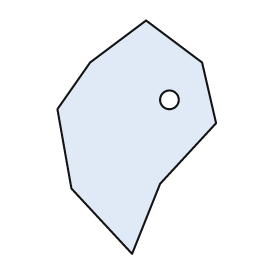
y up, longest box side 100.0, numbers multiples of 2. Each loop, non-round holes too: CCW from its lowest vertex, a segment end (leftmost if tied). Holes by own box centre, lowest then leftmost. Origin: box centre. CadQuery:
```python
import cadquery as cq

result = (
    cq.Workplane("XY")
    .moveTo(-2.0, -50.0)
    .lineTo(10.0, -20.0)
    .lineTo(34.0, 6.0)
    .lineTo(28.0, 32.0)
    .lineTo(4.0, 50.0)
    .lineTo(-20.0, 32.0)
    .lineTo(-34.0, 12.0)
    .lineTo(-28.0, -22.0)
    .close()
    .moveTo(14.0, 16.0)
    .circle(4.0)
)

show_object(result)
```